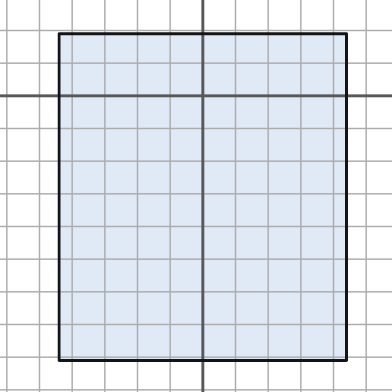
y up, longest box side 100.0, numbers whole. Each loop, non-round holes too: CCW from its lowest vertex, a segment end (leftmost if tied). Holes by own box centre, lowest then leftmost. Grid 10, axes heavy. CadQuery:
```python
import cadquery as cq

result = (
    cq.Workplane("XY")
    .moveTo(-44.0, -81.0)
    .lineTo(44.0, -81.0)
    .lineTo(44.0, 19.0)
    .lineTo(-44.0, 19.0)
    .close()
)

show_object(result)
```